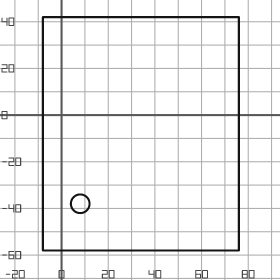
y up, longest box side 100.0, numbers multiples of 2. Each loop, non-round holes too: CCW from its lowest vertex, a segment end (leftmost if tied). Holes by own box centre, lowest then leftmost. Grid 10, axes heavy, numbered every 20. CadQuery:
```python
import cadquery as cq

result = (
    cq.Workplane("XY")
    .moveTo(-8.0, -58.0)
    .lineTo(76.0, -58.0)
    .lineTo(76.0, 42.0)
    .lineTo(-8.0, 42.0)
    .close()
    .moveTo(8.0, -38.0)
    .circle(4.0)
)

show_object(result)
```